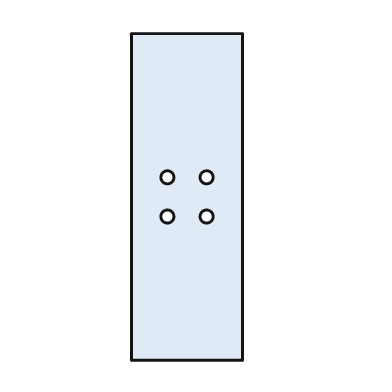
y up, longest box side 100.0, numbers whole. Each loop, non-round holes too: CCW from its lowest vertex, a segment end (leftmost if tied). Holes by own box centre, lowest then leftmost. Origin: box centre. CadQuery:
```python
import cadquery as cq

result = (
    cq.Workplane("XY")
    .moveTo(-17.0, -50.0)
    .lineTo(17.0, -50.0)
    .lineTo(17.0, 50.0)
    .lineTo(-17.0, 50.0)
    .close()
    .moveTo(-6.0, -6.0)
    .circle(2.0)
    .moveTo(6.0, -6.0)
    .circle(2.0)
    .moveTo(-6.0, 6.0)
    .circle(2.0)
    .moveTo(6.0, 6.0)
    .circle(2.0)
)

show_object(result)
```